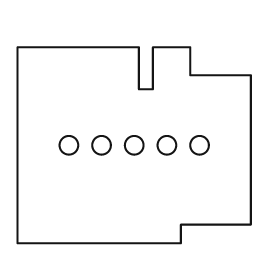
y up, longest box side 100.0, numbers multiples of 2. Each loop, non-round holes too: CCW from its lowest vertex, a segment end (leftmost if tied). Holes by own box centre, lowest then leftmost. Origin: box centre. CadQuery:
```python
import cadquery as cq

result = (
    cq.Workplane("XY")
    .moveTo(-50.0, -42.0)
    .lineTo(20.0, -42.0)
    .lineTo(20.0, -34.0)
    .lineTo(50.0, -34.0)
    .lineTo(50.0, 30.0)
    .lineTo(24.0, 30.0)
    .lineTo(24.0, 42.0)
    .lineTo(8.0, 42.0)
    .lineTo(8.0, 24.0)
    .lineTo(2.0, 24.0)
    .lineTo(2.0, 42.0)
    .lineTo(-50.0, 42.0)
    .close()
    .moveTo(-28.0, 0.0)
    .circle(4.0)
    .moveTo(-14.0, 0.0)
    .circle(4.0)
    .moveTo(0.0, 0.0)
    .circle(4.0)
    .moveTo(14.0, 0.0)
    .circle(4.0)
    .moveTo(28.0, 0.0)
    .circle(4.0)
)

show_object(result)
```